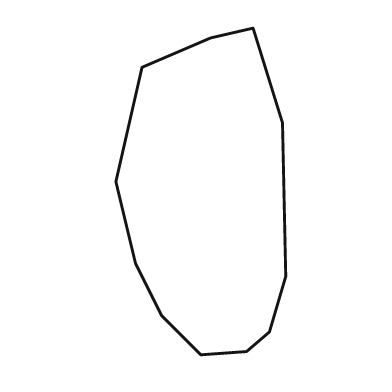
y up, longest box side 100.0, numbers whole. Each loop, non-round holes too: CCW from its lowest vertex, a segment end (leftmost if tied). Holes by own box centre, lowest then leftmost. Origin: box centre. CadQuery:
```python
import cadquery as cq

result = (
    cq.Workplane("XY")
    .moveTo(0.0, -50.0)
    .lineTo(14.0, -49.0)
    .lineTo(21.0, -43.0)
    .lineTo(26.0, -26.0)
    .lineTo(25.0, 21.0)
    .lineTo(16.0, 50.0)
    .lineTo(3.0, 47.0)
    .lineTo(-18.0, 38.0)
    .lineTo(-26.0, 3.0)
    .lineTo(-20.0, -22.0)
    .lineTo(-12.0, -38.0)
    .close()
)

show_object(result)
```